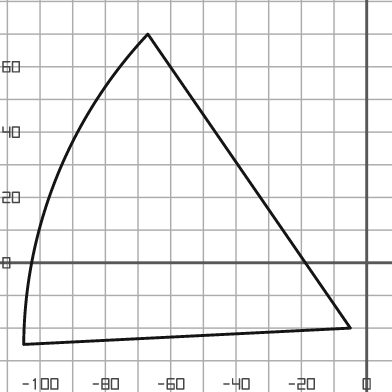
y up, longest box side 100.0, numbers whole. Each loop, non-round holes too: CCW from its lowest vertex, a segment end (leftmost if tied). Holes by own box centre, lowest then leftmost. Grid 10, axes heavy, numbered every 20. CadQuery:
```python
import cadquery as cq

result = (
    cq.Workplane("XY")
    .moveTo(-105.0, -25.0)
    .lineTo(-5.0, -20.0)
    .lineTo(-67.0, 70.0)
    .threePointArc((-95.0, 26.0), (-105.0, -25.0))
    .close()
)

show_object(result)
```